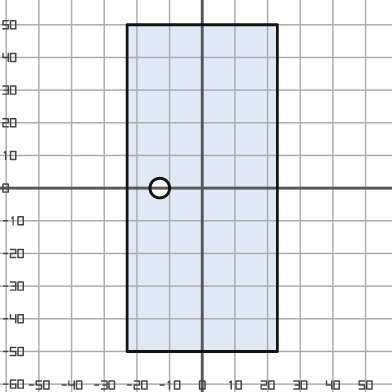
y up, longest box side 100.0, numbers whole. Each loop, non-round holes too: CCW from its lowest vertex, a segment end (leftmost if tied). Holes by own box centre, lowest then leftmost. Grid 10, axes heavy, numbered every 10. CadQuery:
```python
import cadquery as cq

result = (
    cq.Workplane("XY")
    .moveTo(-23.0, -50.0)
    .lineTo(23.0, -50.0)
    .lineTo(23.0, 50.0)
    .lineTo(-23.0, 50.0)
    .close()
    .moveTo(-13.0, 0.0)
    .circle(3.0)
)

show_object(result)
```